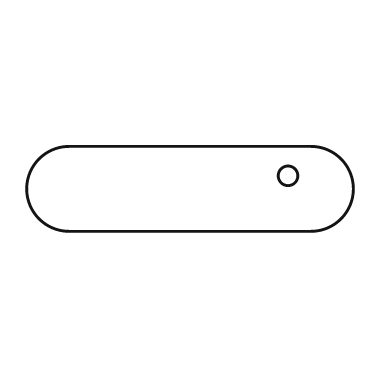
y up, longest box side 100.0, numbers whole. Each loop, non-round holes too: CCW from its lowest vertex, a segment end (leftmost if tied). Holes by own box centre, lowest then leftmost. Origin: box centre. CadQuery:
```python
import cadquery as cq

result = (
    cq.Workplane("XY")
    .moveTo(-37.0, -13.0)
    .lineTo(37.0, -13.0)
    .threePointArc((50.0, 0.0), (37.0, 13.0))
    .lineTo(-37.0, 13.0)
    .threePointArc((-50.0, 0.0), (-37.0, -13.0))
    .close()
    .moveTo(30.0, 4.0)
    .circle(3.0)
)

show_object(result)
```